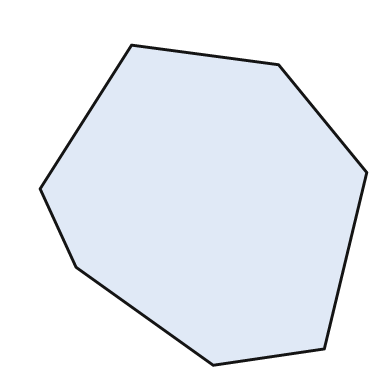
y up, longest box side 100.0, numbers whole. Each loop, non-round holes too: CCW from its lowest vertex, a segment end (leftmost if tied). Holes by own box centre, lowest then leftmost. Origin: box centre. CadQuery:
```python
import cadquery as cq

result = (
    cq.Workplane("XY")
    .moveTo(3.0, -49.0)
    .lineTo(37.0, -44.0)
    .lineTo(50.0, 10.0)
    .lineTo(23.0, 43.0)
    .lineTo(-22.0, 49.0)
    .lineTo(-50.0, 5.0)
    .lineTo(-39.0, -19.0)
    .close()
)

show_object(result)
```